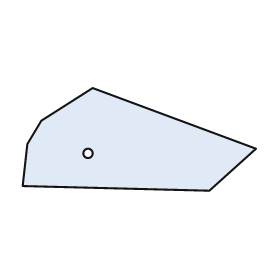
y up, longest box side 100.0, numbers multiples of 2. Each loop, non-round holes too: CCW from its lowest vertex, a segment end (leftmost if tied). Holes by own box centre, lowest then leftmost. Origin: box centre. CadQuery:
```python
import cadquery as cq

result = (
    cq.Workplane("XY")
    .moveTo(30.0, -22.0)
    .lineTo(50.0, -4.0)
    .lineTo(-20.0, 22.0)
    .lineTo(-42.0, 8.0)
    .lineTo(-48.0, -2.0)
    .lineTo(-50.0, -20.0)
    .close()
    .moveTo(-22.0, -6.0)
    .circle(2.0)
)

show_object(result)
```